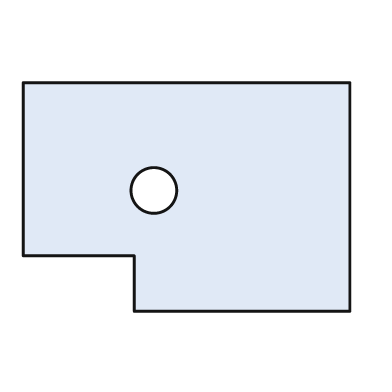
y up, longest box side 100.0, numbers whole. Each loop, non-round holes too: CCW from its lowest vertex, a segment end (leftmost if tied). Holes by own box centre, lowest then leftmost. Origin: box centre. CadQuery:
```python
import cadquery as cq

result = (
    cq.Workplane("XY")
    .moveTo(-16.0, -35.0)
    .lineTo(50.0, -35.0)
    .lineTo(50.0, 35.0)
    .lineTo(-50.0, 35.0)
    .lineTo(-50.0, -18.0)
    .lineTo(-16.0, -18.0)
    .close()
    .moveTo(-10.0, 2.0)
    .circle(7.0)
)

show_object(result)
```